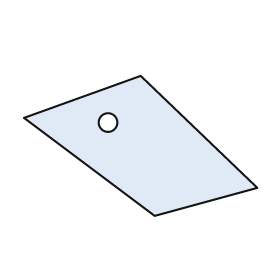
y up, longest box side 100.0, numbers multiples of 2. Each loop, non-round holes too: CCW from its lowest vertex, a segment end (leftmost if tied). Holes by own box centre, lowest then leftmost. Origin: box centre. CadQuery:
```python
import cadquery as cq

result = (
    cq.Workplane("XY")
    .moveTo(6.0, -30.0)
    .lineTo(50.0, -18.0)
    .lineTo(0.0, 30.0)
    .lineTo(-50.0, 12.0)
    .close()
    .moveTo(-14.0, 10.0)
    .circle(4.0)
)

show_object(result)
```